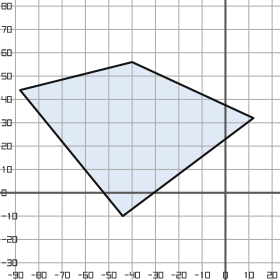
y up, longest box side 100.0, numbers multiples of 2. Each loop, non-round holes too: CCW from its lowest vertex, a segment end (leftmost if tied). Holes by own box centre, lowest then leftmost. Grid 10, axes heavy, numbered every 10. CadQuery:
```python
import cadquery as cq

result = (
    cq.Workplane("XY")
    .moveTo(-44.0, -10.0)
    .lineTo(12.0, 32.0)
    .lineTo(-40.0, 56.0)
    .lineTo(-88.0, 44.0)
    .close()
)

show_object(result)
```